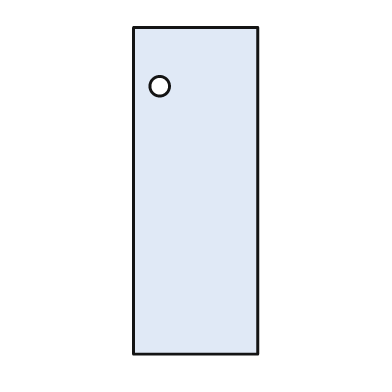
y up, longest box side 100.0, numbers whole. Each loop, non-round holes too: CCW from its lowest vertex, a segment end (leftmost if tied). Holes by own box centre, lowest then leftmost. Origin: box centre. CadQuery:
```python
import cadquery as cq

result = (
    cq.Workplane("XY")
    .moveTo(-19.0, -50.0)
    .lineTo(19.0, -50.0)
    .lineTo(19.0, 50.0)
    .lineTo(-19.0, 50.0)
    .close()
    .moveTo(-11.0, 32.0)
    .circle(3.0)
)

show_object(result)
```